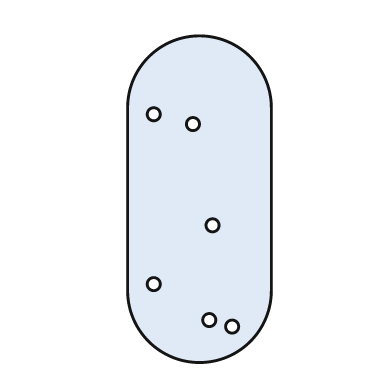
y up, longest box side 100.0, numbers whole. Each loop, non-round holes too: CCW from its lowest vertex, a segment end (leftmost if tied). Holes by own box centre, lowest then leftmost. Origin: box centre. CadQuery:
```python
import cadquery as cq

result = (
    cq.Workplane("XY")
    .moveTo(-22.0, -28.0)
    .threePointArc((0.0, -50.0), (22.0, -28.0))
    .lineTo(22.0, 28.0)
    .threePointArc((0.0, 50.0), (-22.0, 28.0))
    .close()
    .moveTo(10.0, -39.0)
    .circle(2.0)
    .moveTo(3.0, -37.0)
    .circle(2.0)
    .moveTo(-14.0, -26.0)
    .circle(2.0)
    .moveTo(4.0, -8.0)
    .circle(2.0)
    .moveTo(-2.0, 23.0)
    .circle(2.0)
    .moveTo(-14.0, 26.0)
    .circle(2.0)
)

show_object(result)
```